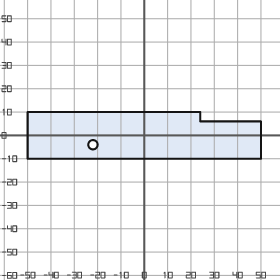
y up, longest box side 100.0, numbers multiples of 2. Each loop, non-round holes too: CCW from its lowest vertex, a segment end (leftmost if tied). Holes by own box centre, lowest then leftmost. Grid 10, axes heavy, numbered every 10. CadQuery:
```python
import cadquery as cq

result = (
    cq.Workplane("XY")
    .moveTo(-50.0, -10.0)
    .lineTo(50.0, -10.0)
    .lineTo(50.0, 6.0)
    .lineTo(24.0, 6.0)
    .lineTo(24.0, 10.0)
    .lineTo(-50.0, 10.0)
    .close()
    .moveTo(-22.0, -4.0)
    .circle(2.0)
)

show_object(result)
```